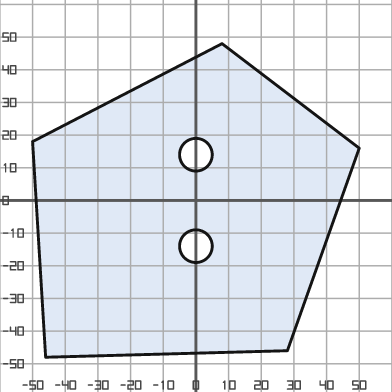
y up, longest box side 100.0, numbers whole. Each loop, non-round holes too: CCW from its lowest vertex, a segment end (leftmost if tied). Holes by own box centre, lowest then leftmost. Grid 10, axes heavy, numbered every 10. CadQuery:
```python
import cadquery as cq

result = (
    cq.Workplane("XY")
    .moveTo(-46.0, -48.0)
    .lineTo(28.0, -46.0)
    .lineTo(50.0, 16.0)
    .lineTo(8.0, 48.0)
    .lineTo(-50.0, 18.0)
    .close()
    .moveTo(0.0, -14.0)
    .circle(5.0)
    .moveTo(0.0, 14.0)
    .circle(5.0)
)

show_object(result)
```